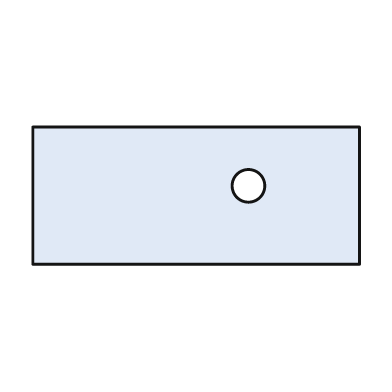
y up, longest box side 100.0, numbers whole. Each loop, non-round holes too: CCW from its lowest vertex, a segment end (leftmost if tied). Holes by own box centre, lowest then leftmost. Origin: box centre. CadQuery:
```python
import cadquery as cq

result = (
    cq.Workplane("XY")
    .moveTo(-50.0, -21.0)
    .lineTo(50.0, -21.0)
    .lineTo(50.0, 21.0)
    .lineTo(-50.0, 21.0)
    .close()
    .moveTo(16.0, 3.0)
    .circle(5.0)
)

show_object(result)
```